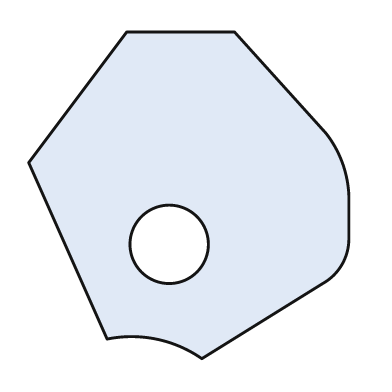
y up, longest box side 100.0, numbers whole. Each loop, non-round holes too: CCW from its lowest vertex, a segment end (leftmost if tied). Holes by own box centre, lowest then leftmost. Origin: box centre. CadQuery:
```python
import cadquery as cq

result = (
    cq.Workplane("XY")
    .moveTo(4.0, -50.0)
    .lineTo(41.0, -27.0)
    .threePointArc((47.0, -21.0), (49.0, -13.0))
    .lineTo(49.0, 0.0)
    .threePointArc((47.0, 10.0), (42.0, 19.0))
    .lineTo(14.0, 50.0)
    .lineTo(-19.0, 50.0)
    .lineTo(-49.0, 10.0)
    .lineTo(-25.0, -44.0)
    .threePointArc((-10.0, -44.0), (4.0, -50.0))
    .close()
    .moveTo(-6.0, -15.0)
    .circle(12.0)
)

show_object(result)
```